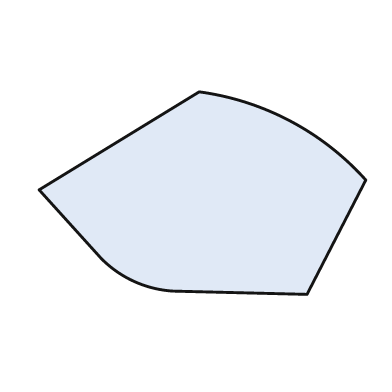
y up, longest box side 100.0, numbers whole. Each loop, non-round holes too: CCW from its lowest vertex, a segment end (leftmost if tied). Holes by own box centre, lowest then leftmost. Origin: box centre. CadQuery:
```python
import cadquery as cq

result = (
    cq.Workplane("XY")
    .moveTo(32.0, -31.0)
    .lineTo(50.0, 4.0)
    .threePointArc((27.0, 22.0), (-1.0, 31.0))
    .lineTo(-50.0, 1.0)
    .lineTo(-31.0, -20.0)
    .threePointArc((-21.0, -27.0), (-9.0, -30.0))
    .close()
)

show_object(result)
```